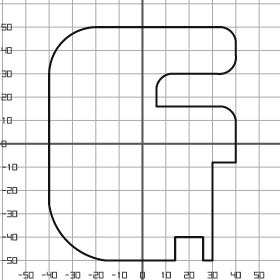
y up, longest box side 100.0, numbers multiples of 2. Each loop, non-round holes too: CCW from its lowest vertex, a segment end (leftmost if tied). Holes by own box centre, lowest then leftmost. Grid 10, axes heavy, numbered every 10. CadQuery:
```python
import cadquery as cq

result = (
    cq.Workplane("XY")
    .moveTo(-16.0, -50.0)
    .lineTo(14.0, -50.0)
    .lineTo(14.0, -40.0)
    .lineTo(26.0, -40.0)
    .lineTo(26.0, -50.0)
    .lineTo(30.0, -50.0)
    .lineTo(30.0, -8.0)
    .lineTo(40.0, -8.0)
    .lineTo(40.0, 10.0)
    .threePointArc((38.0, 14.0), (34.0, 16.0))
    .lineTo(6.0, 16.0)
    .lineTo(6.0, 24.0)
    .threePointArc((8.0, 28.0), (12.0, 30.0))
    .lineTo(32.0, 30.0)
    .threePointArc((38.0, 32.0), (40.0, 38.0))
    .lineTo(40.0, 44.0)
    .threePointArc((38.0, 48.0), (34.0, 50.0))
    .lineTo(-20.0, 50.0)
    .threePointArc((-34.0, 44.0), (-40.0, 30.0))
    .lineTo(-40.0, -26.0)
    .threePointArc((-32.0, -42.0), (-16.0, -50.0))
    .close()
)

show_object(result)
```